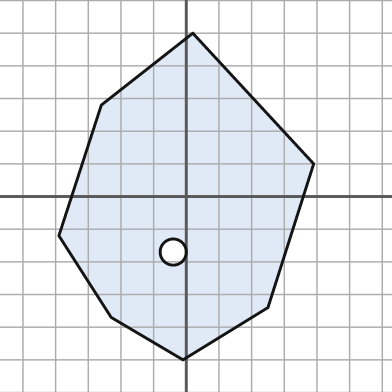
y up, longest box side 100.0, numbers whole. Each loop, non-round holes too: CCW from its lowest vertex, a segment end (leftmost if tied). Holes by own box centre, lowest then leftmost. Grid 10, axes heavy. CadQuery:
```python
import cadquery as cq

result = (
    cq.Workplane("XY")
    .moveTo(-1.0, -50.0)
    .lineTo(25.0, -34.0)
    .lineTo(39.0, 10.0)
    .lineTo(2.0, 50.0)
    .lineTo(-26.0, 28.0)
    .lineTo(-39.0, -12.0)
    .lineTo(-23.0, -37.0)
    .close()
    .moveTo(-4.0, -17.0)
    .circle(4.0)
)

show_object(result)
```